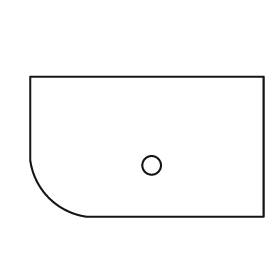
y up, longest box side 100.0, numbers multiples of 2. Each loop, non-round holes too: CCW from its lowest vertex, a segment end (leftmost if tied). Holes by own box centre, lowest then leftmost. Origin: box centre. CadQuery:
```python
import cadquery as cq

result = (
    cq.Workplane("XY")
    .moveTo(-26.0, -30.0)
    .lineTo(50.0, -30.0)
    .lineTo(50.0, 30.0)
    .lineTo(-50.0, 30.0)
    .lineTo(-50.0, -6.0)
    .threePointArc((-42.0, -22.0), (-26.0, -30.0))
    .close()
    .moveTo(2.0, -8.0)
    .circle(4.0)
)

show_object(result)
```